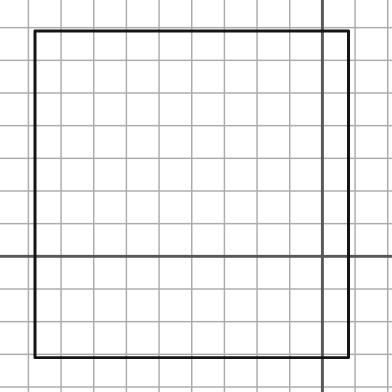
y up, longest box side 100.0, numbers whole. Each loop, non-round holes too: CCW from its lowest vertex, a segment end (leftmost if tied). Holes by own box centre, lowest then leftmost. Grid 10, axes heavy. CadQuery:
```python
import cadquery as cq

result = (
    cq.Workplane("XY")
    .moveTo(-88.0, -31.0)
    .lineTo(8.0, -31.0)
    .lineTo(8.0, 69.0)
    .lineTo(-88.0, 69.0)
    .close()
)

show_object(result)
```